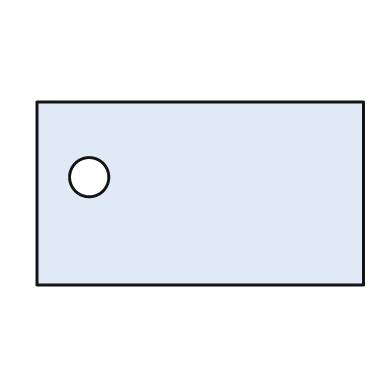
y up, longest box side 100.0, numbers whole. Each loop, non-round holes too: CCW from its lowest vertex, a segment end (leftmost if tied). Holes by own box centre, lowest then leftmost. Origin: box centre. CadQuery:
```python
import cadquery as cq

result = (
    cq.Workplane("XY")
    .moveTo(-50.0, -28.0)
    .lineTo(50.0, -28.0)
    .lineTo(50.0, 28.0)
    .lineTo(-50.0, 28.0)
    .close()
    .moveTo(-34.0, 5.0)
    .circle(6.0)
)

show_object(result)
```